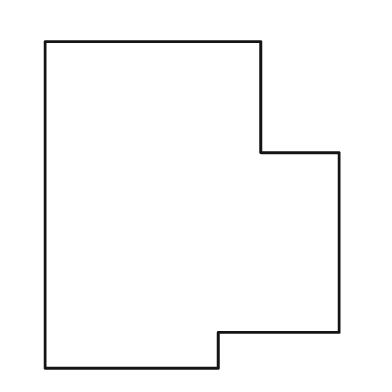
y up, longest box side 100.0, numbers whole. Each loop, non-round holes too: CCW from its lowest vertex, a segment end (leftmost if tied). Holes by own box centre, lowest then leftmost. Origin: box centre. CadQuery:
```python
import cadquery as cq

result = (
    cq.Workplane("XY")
    .moveTo(-45.0, -50.0)
    .lineTo(8.0, -50.0)
    .lineTo(8.0, -39.0)
    .lineTo(45.0, -39.0)
    .lineTo(45.0, 16.0)
    .lineTo(21.0, 16.0)
    .lineTo(21.0, 50.0)
    .lineTo(-45.0, 50.0)
    .close()
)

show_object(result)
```